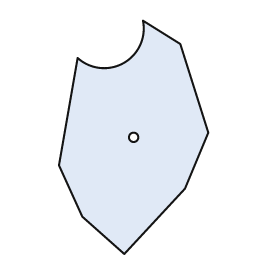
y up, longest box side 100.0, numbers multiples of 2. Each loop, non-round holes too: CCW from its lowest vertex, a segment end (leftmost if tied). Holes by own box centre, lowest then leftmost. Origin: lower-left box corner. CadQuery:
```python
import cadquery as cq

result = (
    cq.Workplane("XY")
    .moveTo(28.0, 0.0)
    .lineTo(54.0, 28.0)
    .lineTo(64.0, 52.0)
    .lineTo(52.0, 90.0)
    .lineTo(36.0, 100.0)
    .threePointArc((28.0, 82.0), (8.0, 84.0))
    .lineTo(0.0, 38.0)
    .lineTo(10.0, 16.0)
    .close()
    .moveTo(32.0, 50.0)
    .circle(2.0)
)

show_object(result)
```